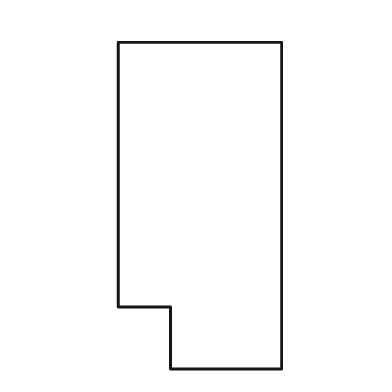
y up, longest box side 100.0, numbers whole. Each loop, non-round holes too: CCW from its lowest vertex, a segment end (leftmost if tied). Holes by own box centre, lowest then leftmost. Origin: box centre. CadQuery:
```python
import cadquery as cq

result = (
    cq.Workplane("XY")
    .moveTo(-9.0, -50.0)
    .lineTo(25.0, -50.0)
    .lineTo(25.0, 50.0)
    .lineTo(-25.0, 50.0)
    .lineTo(-25.0, -31.0)
    .lineTo(-9.0, -31.0)
    .close()
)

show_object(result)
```